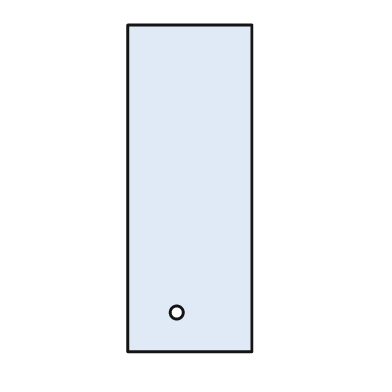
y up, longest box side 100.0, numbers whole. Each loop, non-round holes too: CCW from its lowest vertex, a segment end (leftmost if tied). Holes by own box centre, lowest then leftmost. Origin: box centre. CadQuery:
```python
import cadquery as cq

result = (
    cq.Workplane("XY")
    .moveTo(-19.0, -50.0)
    .lineTo(19.0, -50.0)
    .lineTo(19.0, 50.0)
    .lineTo(-19.0, 50.0)
    .close()
    .moveTo(-4.0, -38.0)
    .circle(2.0)
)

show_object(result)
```